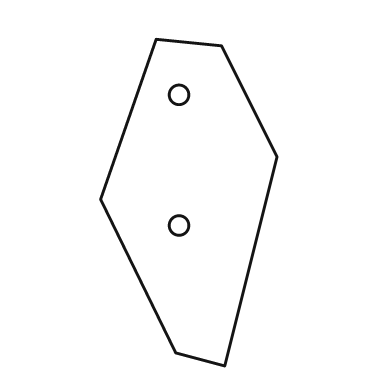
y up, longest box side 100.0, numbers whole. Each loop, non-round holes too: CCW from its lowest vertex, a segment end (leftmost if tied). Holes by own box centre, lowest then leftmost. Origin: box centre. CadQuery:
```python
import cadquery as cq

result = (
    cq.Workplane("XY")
    .moveTo(11.0, -50.0)
    .lineTo(27.0, 14.0)
    .lineTo(10.0, 48.0)
    .lineTo(-10.0, 50.0)
    .lineTo(-27.0, 1.0)
    .lineTo(-4.0, -46.0)
    .close()
    .moveTo(-3.0, -7.0)
    .circle(3.0)
    .moveTo(-3.0, 33.0)
    .circle(3.0)
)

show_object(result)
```